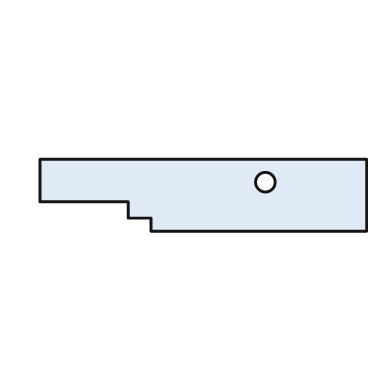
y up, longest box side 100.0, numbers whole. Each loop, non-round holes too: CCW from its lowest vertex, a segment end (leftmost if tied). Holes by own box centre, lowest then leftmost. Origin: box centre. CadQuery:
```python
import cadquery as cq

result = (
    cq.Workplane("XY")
    .moveTo(-16.0, -11.0)
    .lineTo(50.0, -11.0)
    .lineTo(50.0, 11.0)
    .lineTo(-50.0, 11.0)
    .lineTo(-50.0, -2.0)
    .lineTo(-23.0, -2.0)
    .lineTo(-23.0, -7.0)
    .lineTo(-16.0, -7.0)
    .close()
    .moveTo(19.0, 4.0)
    .circle(3.0)
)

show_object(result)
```